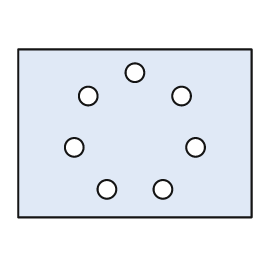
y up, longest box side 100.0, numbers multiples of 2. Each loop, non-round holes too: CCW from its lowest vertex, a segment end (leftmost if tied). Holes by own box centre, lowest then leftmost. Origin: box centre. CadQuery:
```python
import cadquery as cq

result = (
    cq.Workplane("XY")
    .moveTo(-50.0, -36.0)
    .lineTo(50.0, -36.0)
    .lineTo(50.0, 36.0)
    .lineTo(-50.0, 36.0)
    .close()
    .moveTo(-12.0, -24.0)
    .circle(4.0)
    .moveTo(12.0, -24.0)
    .circle(4.0)
    .moveTo(-26.0, -6.0)
    .circle(4.0)
    .moveTo(26.0, -6.0)
    .circle(4.0)
    .moveTo(-20.0, 16.0)
    .circle(4.0)
    .moveTo(20.0, 16.0)
    .circle(4.0)
    .moveTo(0.0, 26.0)
    .circle(4.0)
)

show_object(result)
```